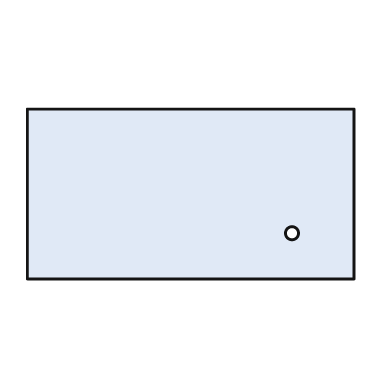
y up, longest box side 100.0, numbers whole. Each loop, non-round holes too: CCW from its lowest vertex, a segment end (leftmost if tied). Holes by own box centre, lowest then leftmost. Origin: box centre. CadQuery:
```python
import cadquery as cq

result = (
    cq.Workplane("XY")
    .moveTo(-50.0, -26.0)
    .lineTo(50.0, -26.0)
    .lineTo(50.0, 26.0)
    .lineTo(-50.0, 26.0)
    .close()
    .moveTo(31.0, -12.0)
    .circle(2.0)
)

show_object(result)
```